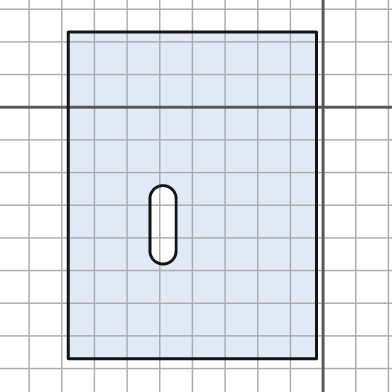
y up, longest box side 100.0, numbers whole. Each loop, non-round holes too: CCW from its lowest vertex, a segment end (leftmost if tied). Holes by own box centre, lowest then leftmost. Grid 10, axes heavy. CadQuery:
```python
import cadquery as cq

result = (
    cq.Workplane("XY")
    .moveTo(-78.0, -77.0)
    .lineTo(-2.0, -77.0)
    .lineTo(-2.0, 23.0)
    .lineTo(-78.0, 23.0)
    .close()
    .moveTo(-53.0, -44.0)
    .threePointArc((-49.0, -48.0), (-45.0, -44.0))
    .lineTo(-45.0, -28.0)
    .threePointArc((-49.0, -24.0), (-53.0, -28.0))
    .close()
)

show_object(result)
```